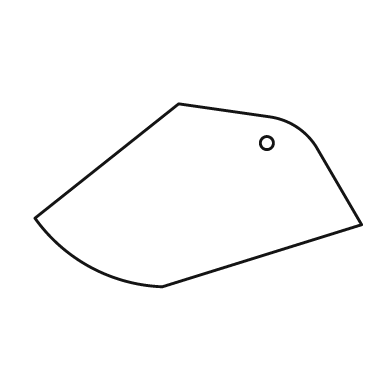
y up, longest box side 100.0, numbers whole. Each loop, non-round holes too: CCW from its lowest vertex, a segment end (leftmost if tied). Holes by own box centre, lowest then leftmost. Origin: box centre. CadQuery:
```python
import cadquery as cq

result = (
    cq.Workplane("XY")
    .moveTo(-11.0, -28.0)
    .lineTo(50.0, -9.0)
    .lineTo(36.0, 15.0)
    .threePointArc((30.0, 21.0), (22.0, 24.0))
    .lineTo(-6.0, 28.0)
    .lineTo(-50.0, -7.0)
    .threePointArc((-33.0, -22.0), (-11.0, -28.0))
    .close()
    .moveTo(21.0, 16.0)
    .circle(2.0)
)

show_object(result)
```